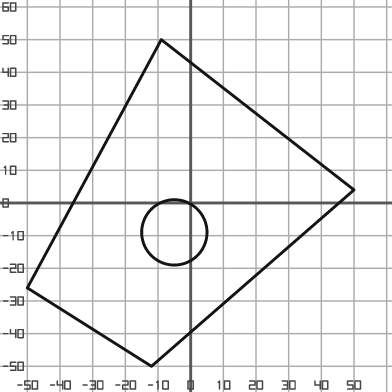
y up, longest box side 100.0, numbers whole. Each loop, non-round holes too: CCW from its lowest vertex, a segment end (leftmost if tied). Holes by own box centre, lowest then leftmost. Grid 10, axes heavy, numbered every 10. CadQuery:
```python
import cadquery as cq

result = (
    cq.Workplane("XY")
    .moveTo(-12.0, -50.0)
    .lineTo(50.0, 4.0)
    .lineTo(-9.0, 50.0)
    .lineTo(-50.0, -26.0)
    .close()
    .moveTo(-5.0, -9.0)
    .circle(10.0)
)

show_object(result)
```